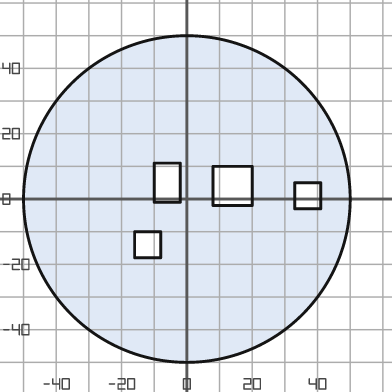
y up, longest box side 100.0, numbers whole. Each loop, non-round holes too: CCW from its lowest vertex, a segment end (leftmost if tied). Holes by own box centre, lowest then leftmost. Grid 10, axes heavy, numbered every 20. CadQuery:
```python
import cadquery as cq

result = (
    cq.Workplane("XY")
    .moveTo(0.0, 0.0)
    .circle(50.0)
    .moveTo(-16.0, -18.0)
    .lineTo(-8.0, -18.0)
    .lineTo(-8.0, -10.0)
    .lineTo(-16.0, -10.0)
    .close()
    .moveTo(33.0, -3.0)
    .lineTo(41.0, -3.0)
    .lineTo(41.0, 5.0)
    .lineTo(33.0, 5.0)
    .close()
    .moveTo(8.0, -2.0)
    .lineTo(20.0, -2.0)
    .lineTo(20.0, 10.0)
    .lineTo(8.0, 10.0)
    .close()
    .moveTo(-10.0, -1.0)
    .lineTo(-2.0, -1.0)
    .lineTo(-2.0, 11.0)
    .lineTo(-10.0, 11.0)
    .close()
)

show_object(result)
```